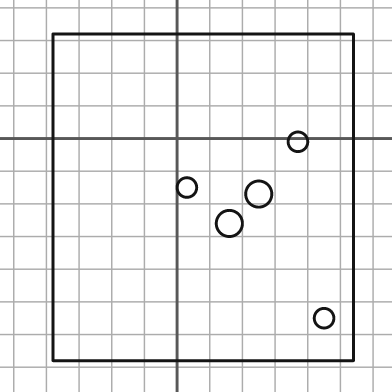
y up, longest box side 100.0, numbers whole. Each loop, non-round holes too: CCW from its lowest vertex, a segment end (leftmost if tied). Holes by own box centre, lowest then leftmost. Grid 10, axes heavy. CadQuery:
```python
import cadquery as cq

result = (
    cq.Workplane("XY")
    .moveTo(-38.0, -68.0)
    .lineTo(54.0, -68.0)
    .lineTo(54.0, 32.0)
    .lineTo(-38.0, 32.0)
    .close()
    .moveTo(45.0, -55.0)
    .circle(3.0)
    .moveTo(16.0, -26.0)
    .circle(4.0)
    .moveTo(25.0, -17.0)
    .circle(4.0)
    .moveTo(3.0, -15.0)
    .circle(3.0)
    .moveTo(37.0, -1.0)
    .circle(3.0)
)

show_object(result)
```